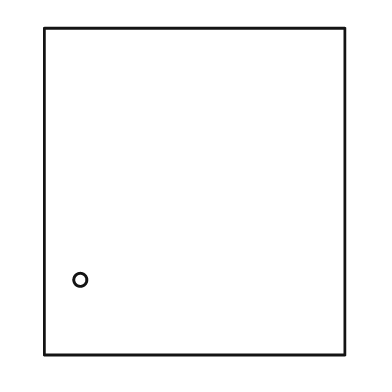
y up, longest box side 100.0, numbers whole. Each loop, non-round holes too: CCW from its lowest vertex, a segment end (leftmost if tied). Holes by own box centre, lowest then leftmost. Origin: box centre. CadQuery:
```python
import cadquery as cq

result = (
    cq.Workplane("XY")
    .moveTo(-46.0, -50.0)
    .lineTo(46.0, -50.0)
    .lineTo(46.0, 50.0)
    .lineTo(-46.0, 50.0)
    .close()
    .moveTo(-35.0, -27.0)
    .circle(2.0)
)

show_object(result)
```